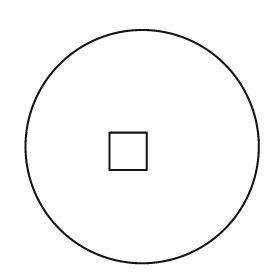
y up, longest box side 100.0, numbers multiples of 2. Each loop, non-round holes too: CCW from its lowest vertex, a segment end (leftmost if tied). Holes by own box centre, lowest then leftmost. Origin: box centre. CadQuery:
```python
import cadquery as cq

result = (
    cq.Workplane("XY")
    .moveTo(0.0, 0.0)
    .circle(50.0)
    .moveTo(-14.0, -10.0)
    .lineTo(2.0, -10.0)
    .lineTo(2.0, 6.0)
    .lineTo(-14.0, 6.0)
    .close()
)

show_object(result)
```